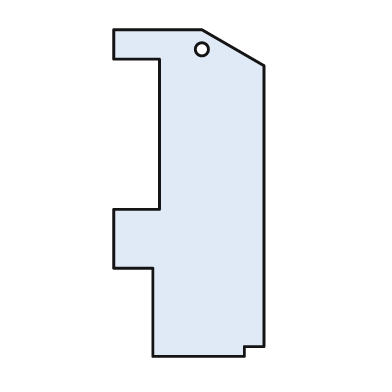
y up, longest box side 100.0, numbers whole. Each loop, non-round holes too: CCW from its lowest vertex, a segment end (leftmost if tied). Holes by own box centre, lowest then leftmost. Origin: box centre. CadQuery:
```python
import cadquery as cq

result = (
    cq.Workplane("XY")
    .moveTo(-11.0, -50.0)
    .lineTo(17.0, -50.0)
    .lineTo(17.0, -47.0)
    .lineTo(23.0, -47.0)
    .lineTo(23.0, 39.0)
    .lineTo(4.0, 50.0)
    .lineTo(-23.0, 50.0)
    .lineTo(-23.0, 41.0)
    .lineTo(-9.0, 41.0)
    .lineTo(-9.0, -5.0)
    .lineTo(-23.0, -5.0)
    .lineTo(-23.0, -23.0)
    .lineTo(-11.0, -23.0)
    .close()
    .moveTo(4.0, 44.0)
    .circle(2.0)
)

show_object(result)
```